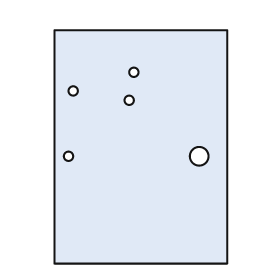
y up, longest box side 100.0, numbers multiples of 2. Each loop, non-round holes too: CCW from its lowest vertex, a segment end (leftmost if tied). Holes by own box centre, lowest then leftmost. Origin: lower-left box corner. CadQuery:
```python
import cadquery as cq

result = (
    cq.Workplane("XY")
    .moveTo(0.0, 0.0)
    .lineTo(74.0, 0.0)
    .lineTo(74.0, 100.0)
    .lineTo(0.0, 100.0)
    .close()
    .moveTo(6.0, 46.0)
    .circle(2.0)
    .moveTo(62.0, 46.0)
    .circle(4.0)
    .moveTo(32.0, 70.0)
    .circle(2.0)
    .moveTo(8.0, 74.0)
    .circle(2.0)
    .moveTo(34.0, 82.0)
    .circle(2.0)
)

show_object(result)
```